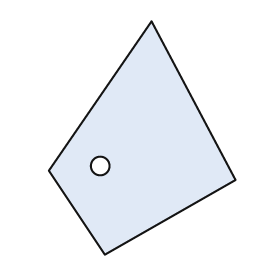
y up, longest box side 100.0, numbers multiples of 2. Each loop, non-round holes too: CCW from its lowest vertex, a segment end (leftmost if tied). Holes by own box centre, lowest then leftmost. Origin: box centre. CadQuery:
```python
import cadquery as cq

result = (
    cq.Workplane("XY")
    .moveTo(-16.0, -50.0)
    .lineTo(40.0, -18.0)
    .lineTo(4.0, 50.0)
    .lineTo(-40.0, -14.0)
    .close()
    .moveTo(-18.0, -12.0)
    .circle(4.0)
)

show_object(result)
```